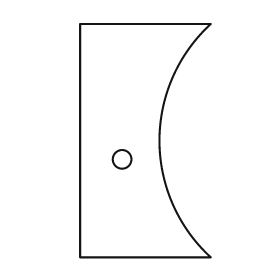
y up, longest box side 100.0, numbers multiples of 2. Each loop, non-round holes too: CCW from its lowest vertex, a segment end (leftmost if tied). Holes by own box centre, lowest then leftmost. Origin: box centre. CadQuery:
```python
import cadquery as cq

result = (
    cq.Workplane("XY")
    .moveTo(-28.0, -50.0)
    .lineTo(28.0, -50.0)
    .threePointArc((6.0, 0.0), (28.0, 50.0))
    .lineTo(-28.0, 50.0)
    .close()
    .moveTo(-10.0, -8.0)
    .circle(4.0)
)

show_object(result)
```